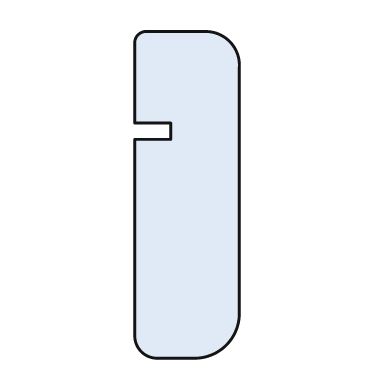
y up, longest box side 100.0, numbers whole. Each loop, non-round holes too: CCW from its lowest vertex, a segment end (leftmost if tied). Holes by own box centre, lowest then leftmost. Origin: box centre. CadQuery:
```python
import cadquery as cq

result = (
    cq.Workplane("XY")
    .moveTo(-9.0, -50.0)
    .lineTo(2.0, -50.0)
    .threePointArc((12.0, -46.0), (16.0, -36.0))
    .lineTo(16.0, 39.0)
    .threePointArc((13.0, 47.0), (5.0, 50.0))
    .lineTo(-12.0, 50.0)
    .threePointArc((-15.0, 49.0), (-16.0, 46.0))
    .lineTo(-16.0, 22.0)
    .lineTo(-5.0, 22.0)
    .lineTo(-5.0, 17.0)
    .lineTo(-16.0, 17.0)
    .lineTo(-16.0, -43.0)
    .threePointArc((-14.0, -48.0), (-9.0, -50.0))
    .close()
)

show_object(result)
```